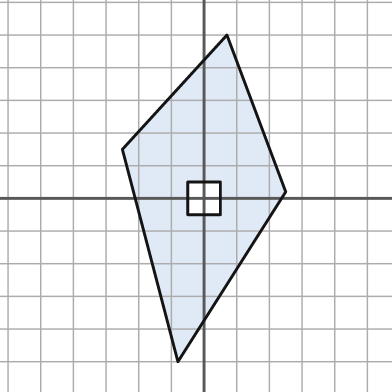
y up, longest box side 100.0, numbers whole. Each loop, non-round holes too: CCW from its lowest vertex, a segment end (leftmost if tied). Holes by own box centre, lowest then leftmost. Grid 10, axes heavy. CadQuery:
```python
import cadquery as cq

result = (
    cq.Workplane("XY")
    .moveTo(-8.0, -50.0)
    .lineTo(25.0, 2.0)
    .lineTo(7.0, 50.0)
    .lineTo(-25.0, 15.0)
    .close()
    .moveTo(-5.0, -5.0)
    .lineTo(5.0, -5.0)
    .lineTo(5.0, 5.0)
    .lineTo(-5.0, 5.0)
    .close()
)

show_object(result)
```